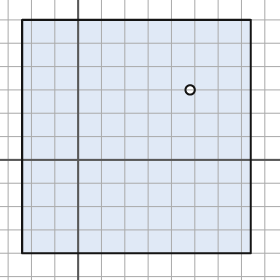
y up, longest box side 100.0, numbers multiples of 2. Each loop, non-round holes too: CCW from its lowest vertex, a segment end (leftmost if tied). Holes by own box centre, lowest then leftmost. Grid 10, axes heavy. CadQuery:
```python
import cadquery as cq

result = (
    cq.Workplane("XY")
    .moveTo(-24.0, -40.0)
    .lineTo(74.0, -40.0)
    .lineTo(74.0, 60.0)
    .lineTo(-24.0, 60.0)
    .close()
    .moveTo(48.0, 30.0)
    .circle(2.0)
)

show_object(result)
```